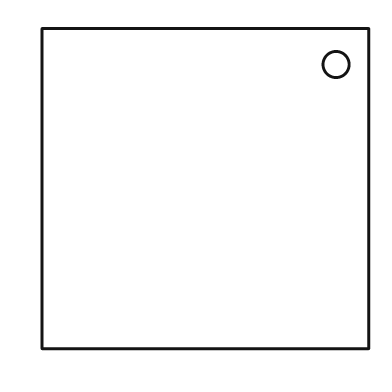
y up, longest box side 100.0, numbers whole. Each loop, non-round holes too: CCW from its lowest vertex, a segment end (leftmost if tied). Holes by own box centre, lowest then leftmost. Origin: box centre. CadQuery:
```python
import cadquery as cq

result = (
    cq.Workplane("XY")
    .moveTo(-50.0, -49.0)
    .lineTo(50.0, -49.0)
    .lineTo(50.0, 49.0)
    .lineTo(-50.0, 49.0)
    .close()
    .moveTo(40.0, 38.0)
    .circle(4.0)
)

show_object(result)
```